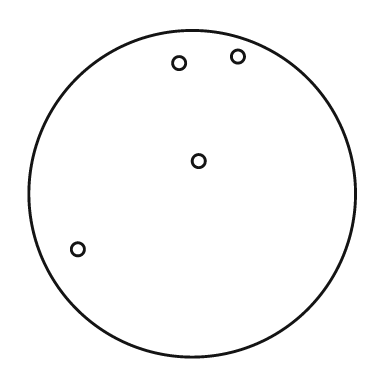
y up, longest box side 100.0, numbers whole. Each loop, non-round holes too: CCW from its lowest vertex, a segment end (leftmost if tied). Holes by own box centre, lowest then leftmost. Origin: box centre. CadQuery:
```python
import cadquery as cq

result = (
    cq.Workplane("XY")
    .moveTo(0.0, 0.0)
    .circle(50.0)
    .moveTo(-35.0, -17.0)
    .circle(2.0)
    .moveTo(2.0, 10.0)
    .circle(2.0)
    .moveTo(-4.0, 40.0)
    .circle(2.0)
    .moveTo(14.0, 42.0)
    .circle(2.0)
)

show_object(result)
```